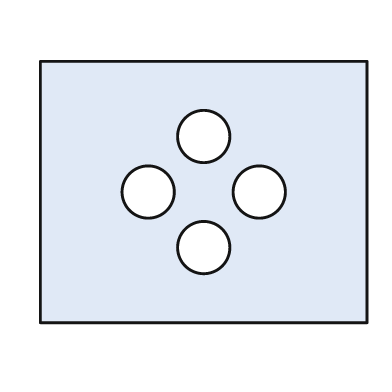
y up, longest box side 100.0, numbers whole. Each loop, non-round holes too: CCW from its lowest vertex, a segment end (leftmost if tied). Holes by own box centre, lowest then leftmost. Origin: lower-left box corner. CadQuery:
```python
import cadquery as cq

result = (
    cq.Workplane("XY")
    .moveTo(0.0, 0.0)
    .lineTo(100.0, 0.0)
    .lineTo(100.0, 80.0)
    .lineTo(0.0, 80.0)
    .close()
    .moveTo(50.0, 23.0)
    .circle(8.0)
    .moveTo(33.0, 40.0)
    .circle(8.0)
    .moveTo(67.0, 40.0)
    .circle(8.0)
    .moveTo(50.0, 57.0)
    .circle(8.0)
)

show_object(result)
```